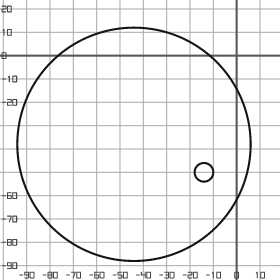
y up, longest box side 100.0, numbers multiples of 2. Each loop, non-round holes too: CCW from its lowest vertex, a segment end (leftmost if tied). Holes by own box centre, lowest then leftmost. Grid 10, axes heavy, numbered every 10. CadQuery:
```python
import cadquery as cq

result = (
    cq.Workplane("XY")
    .moveTo(-44.0, -38.0)
    .circle(50.0)
    .moveTo(-14.0, -50.0)
    .circle(4.0)
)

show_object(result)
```